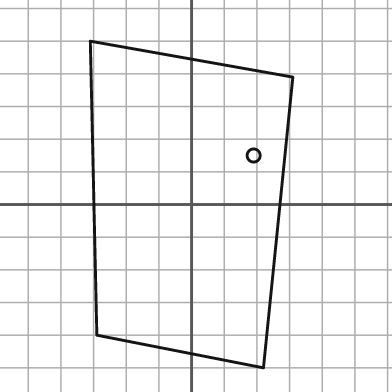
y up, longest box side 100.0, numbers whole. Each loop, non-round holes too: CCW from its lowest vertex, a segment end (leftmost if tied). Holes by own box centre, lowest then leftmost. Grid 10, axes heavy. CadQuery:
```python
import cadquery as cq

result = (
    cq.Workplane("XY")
    .moveTo(22.0, -50.0)
    .lineTo(31.0, 39.0)
    .lineTo(-31.0, 50.0)
    .lineTo(-29.0, -40.0)
    .close()
    .moveTo(19.0, 15.0)
    .circle(2.0)
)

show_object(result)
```